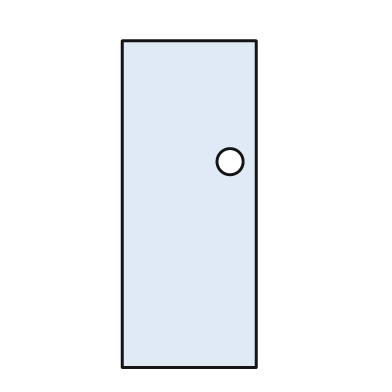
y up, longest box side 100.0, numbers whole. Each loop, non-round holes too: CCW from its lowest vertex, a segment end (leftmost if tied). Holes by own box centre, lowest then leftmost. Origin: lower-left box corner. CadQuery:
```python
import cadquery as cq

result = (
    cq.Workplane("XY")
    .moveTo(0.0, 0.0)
    .lineTo(41.0, 0.0)
    .lineTo(41.0, 100.0)
    .lineTo(0.0, 100.0)
    .close()
    .moveTo(33.0, 63.0)
    .circle(4.0)
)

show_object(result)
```